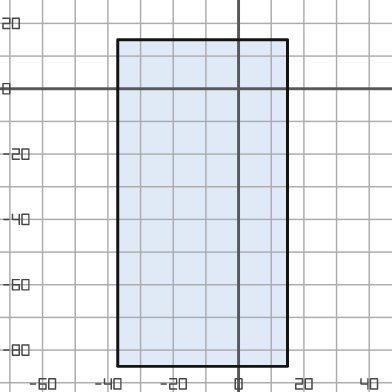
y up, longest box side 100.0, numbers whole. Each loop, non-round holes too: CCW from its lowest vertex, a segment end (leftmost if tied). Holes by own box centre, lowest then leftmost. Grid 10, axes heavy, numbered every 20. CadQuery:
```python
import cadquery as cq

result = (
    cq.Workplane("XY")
    .moveTo(-37.0, -85.0)
    .lineTo(15.0, -85.0)
    .lineTo(15.0, 15.0)
    .lineTo(-37.0, 15.0)
    .close()
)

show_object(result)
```